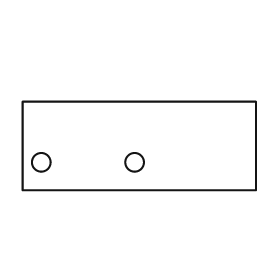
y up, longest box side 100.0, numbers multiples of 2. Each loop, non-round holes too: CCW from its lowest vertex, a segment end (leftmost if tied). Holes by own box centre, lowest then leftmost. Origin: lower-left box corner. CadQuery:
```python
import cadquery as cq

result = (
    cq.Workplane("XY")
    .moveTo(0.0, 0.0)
    .lineTo(100.0, 0.0)
    .lineTo(100.0, 38.0)
    .lineTo(0.0, 38.0)
    .close()
    .moveTo(8.0, 12.0)
    .circle(4.0)
    .moveTo(48.0, 12.0)
    .circle(4.0)
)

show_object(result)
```